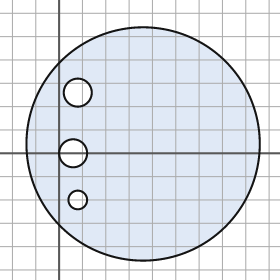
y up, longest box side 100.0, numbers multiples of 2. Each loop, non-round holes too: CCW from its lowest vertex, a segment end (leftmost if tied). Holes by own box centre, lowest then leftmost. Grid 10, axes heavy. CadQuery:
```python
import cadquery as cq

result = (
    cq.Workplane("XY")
    .moveTo(36.0, 4.0)
    .circle(50.0)
    .moveTo(8.0, -20.0)
    .circle(4.0)
    .moveTo(6.0, 0.0)
    .circle(6.0)
    .moveTo(8.0, 26.0)
    .circle(6.0)
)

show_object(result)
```